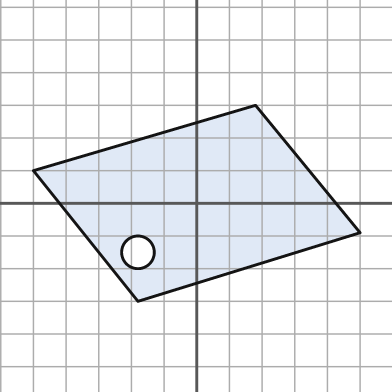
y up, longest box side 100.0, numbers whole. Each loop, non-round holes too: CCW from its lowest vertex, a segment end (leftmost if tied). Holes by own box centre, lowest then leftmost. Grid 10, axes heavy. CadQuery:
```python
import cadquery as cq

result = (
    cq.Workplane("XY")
    .moveTo(-18.0, -30.0)
    .lineTo(50.0, -9.0)
    .lineTo(18.0, 30.0)
    .lineTo(-50.0, 10.0)
    .close()
    .moveTo(-18.0, -15.0)
    .circle(5.0)
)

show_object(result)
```